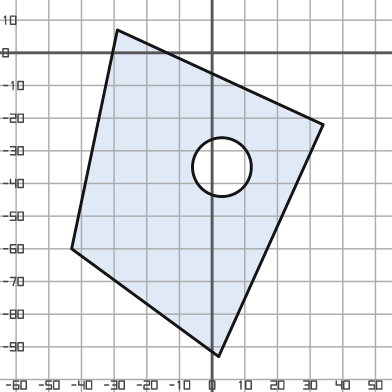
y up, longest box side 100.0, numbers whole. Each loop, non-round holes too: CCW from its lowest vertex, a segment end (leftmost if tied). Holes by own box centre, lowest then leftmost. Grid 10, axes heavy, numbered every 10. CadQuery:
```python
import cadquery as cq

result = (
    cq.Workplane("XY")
    .moveTo(2.0, -93.0)
    .lineTo(34.0, -22.0)
    .lineTo(-29.0, 7.0)
    .lineTo(-43.0, -60.0)
    .close()
    .moveTo(3.0, -35.0)
    .circle(9.0)
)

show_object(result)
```